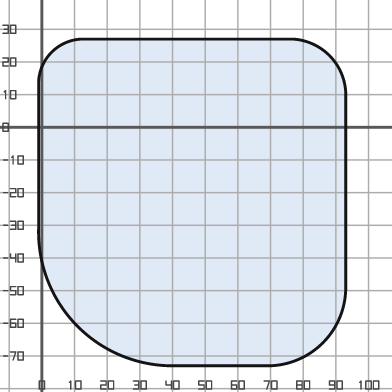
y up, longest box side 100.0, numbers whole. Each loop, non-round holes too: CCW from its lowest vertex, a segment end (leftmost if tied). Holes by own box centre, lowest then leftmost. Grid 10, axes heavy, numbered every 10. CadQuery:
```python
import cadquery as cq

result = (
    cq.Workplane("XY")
    .moveTo(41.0, -73.0)
    .lineTo(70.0, -73.0)
    .threePointArc((86.0, -66.0), (93.0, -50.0))
    .lineTo(93.0, 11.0)
    .threePointArc((88.0, 22.0), (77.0, 27.0))
    .lineTo(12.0, 27.0)
    .threePointArc((3.0, 23.0), (-1.0, 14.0))
    .lineTo(-1.0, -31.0)
    .threePointArc((11.0, -61.0), (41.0, -73.0))
    .close()
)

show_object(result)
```